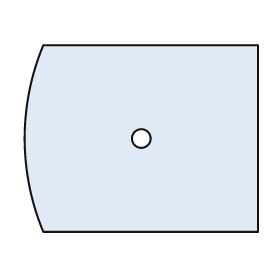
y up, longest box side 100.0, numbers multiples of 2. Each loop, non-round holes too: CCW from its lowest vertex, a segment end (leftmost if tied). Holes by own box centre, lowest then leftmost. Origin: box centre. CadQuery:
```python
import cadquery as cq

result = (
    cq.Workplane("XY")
    .moveTo(-42.0, -40.0)
    .lineTo(50.0, -40.0)
    .lineTo(50.0, 40.0)
    .lineTo(-42.0, 40.0)
    .threePointArc((-50.0, 0.0), (-42.0, -40.0))
    .close()
    .moveTo(0.0, 0.0)
    .circle(4.0)
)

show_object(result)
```